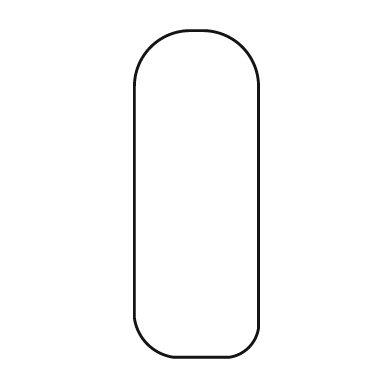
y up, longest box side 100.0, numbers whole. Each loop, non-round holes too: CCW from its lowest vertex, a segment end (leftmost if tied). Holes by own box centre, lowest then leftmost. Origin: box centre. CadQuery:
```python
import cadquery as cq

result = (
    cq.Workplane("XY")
    .moveTo(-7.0, -50.0)
    .lineTo(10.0, -50.0)
    .threePointArc((16.0, -47.0), (19.0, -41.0))
    .lineTo(19.0, 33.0)
    .threePointArc((14.0, 45.0), (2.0, 50.0))
    .lineTo(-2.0, 50.0)
    .threePointArc((-14.0, 45.0), (-19.0, 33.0))
    .lineTo(-19.0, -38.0)
    .threePointArc((-15.0, -46.0), (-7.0, -50.0))
    .close()
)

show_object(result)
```